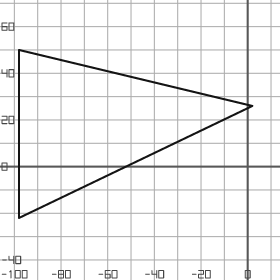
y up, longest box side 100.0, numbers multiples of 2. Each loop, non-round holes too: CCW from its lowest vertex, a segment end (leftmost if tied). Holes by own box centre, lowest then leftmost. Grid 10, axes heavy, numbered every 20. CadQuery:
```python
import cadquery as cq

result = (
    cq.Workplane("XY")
    .moveTo(-98.0, -22.0)
    .lineTo(2.0, 26.0)
    .lineTo(-98.0, 50.0)
    .close()
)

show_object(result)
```